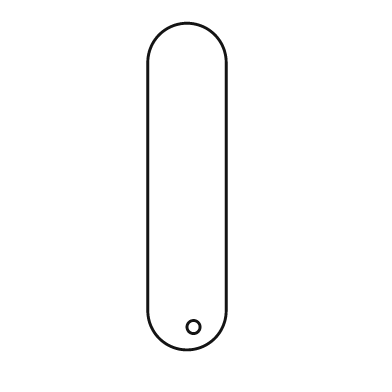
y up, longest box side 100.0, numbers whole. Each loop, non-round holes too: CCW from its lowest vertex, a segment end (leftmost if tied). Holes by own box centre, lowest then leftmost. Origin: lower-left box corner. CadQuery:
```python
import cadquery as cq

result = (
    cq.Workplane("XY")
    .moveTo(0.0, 12.0)
    .threePointArc((12.0, 0.0), (24.0, 12.0))
    .lineTo(24.0, 88.0)
    .threePointArc((12.0, 100.0), (0.0, 88.0))
    .close()
    .moveTo(14.0, 7.0)
    .circle(2.0)
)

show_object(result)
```